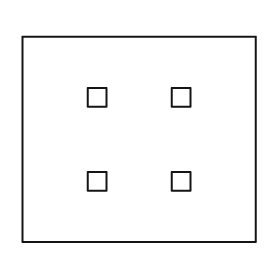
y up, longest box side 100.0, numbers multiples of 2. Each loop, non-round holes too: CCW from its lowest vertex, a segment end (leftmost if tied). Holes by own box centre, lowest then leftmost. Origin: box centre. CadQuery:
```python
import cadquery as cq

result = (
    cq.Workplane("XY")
    .moveTo(-50.0, -44.0)
    .lineTo(50.0, -44.0)
    .lineTo(50.0, 44.0)
    .lineTo(-50.0, 44.0)
    .close()
    .moveTo(-22.0, -22.0)
    .lineTo(-14.0, -22.0)
    .lineTo(-14.0, -14.0)
    .lineTo(-22.0, -14.0)
    .close()
    .moveTo(14.0, -22.0)
    .lineTo(22.0, -22.0)
    .lineTo(22.0, -14.0)
    .lineTo(14.0, -14.0)
    .close()
    .moveTo(-22.0, 14.0)
    .lineTo(-14.0, 14.0)
    .lineTo(-14.0, 22.0)
    .lineTo(-22.0, 22.0)
    .close()
    .moveTo(14.0, 14.0)
    .lineTo(22.0, 14.0)
    .lineTo(22.0, 22.0)
    .lineTo(14.0, 22.0)
    .close()
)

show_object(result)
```